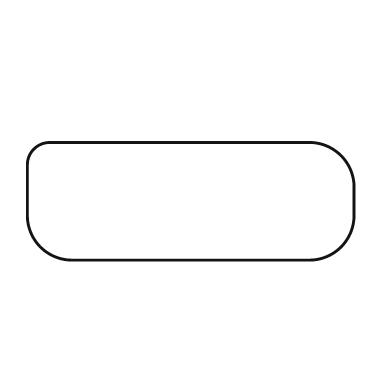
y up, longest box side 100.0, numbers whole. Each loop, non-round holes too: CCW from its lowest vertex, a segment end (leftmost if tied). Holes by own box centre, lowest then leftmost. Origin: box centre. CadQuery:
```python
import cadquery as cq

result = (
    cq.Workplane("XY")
    .moveTo(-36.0, -18.0)
    .lineTo(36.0, -18.0)
    .threePointArc((46.0, -14.0), (50.0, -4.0))
    .lineTo(50.0, 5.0)
    .threePointArc((46.0, 14.0), (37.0, 18.0))
    .lineTo(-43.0, 18.0)
    .threePointArc((-48.0, 16.0), (-50.0, 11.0))
    .lineTo(-50.0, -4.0)
    .threePointArc((-46.0, -14.0), (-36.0, -18.0))
    .close()
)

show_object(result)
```